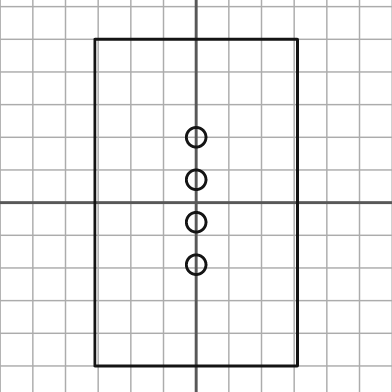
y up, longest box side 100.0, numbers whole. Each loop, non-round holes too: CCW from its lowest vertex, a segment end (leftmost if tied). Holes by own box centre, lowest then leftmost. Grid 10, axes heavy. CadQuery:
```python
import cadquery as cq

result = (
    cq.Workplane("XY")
    .moveTo(-31.0, -50.0)
    .lineTo(31.0, -50.0)
    .lineTo(31.0, 50.0)
    .lineTo(-31.0, 50.0)
    .close()
    .moveTo(0.0, -19.0)
    .circle(3.0)
    .moveTo(0.0, -6.0)
    .circle(3.0)
    .moveTo(0.0, 7.0)
    .circle(3.0)
    .moveTo(0.0, 20.0)
    .circle(3.0)
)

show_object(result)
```